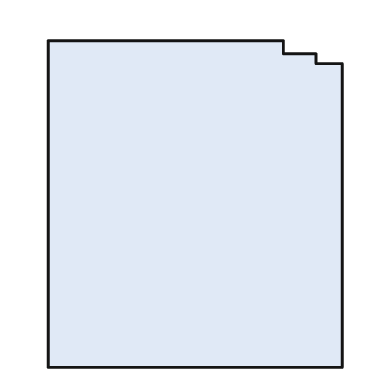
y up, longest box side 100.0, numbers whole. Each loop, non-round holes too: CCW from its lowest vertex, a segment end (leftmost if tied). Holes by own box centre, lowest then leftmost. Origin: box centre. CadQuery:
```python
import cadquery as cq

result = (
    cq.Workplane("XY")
    .moveTo(-45.0, -50.0)
    .lineTo(45.0, -50.0)
    .lineTo(45.0, 43.0)
    .lineTo(37.0, 43.0)
    .lineTo(37.0, 46.0)
    .lineTo(27.0, 46.0)
    .lineTo(27.0, 50.0)
    .lineTo(-45.0, 50.0)
    .close()
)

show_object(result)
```